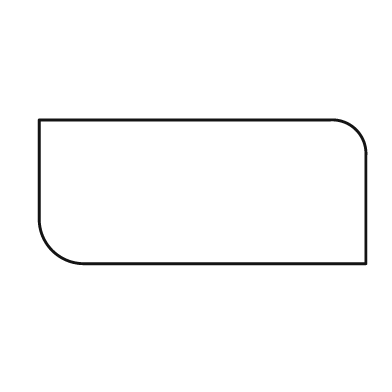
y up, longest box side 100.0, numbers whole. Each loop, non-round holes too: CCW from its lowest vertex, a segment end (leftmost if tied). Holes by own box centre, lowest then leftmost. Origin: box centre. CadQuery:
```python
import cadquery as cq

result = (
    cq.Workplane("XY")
    .moveTo(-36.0, -22.0)
    .lineTo(50.0, -22.0)
    .lineTo(50.0, 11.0)
    .threePointArc((47.0, 19.0), (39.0, 22.0))
    .lineTo(-50.0, 22.0)
    .lineTo(-50.0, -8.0)
    .threePointArc((-46.0, -18.0), (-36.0, -22.0))
    .close()
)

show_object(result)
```